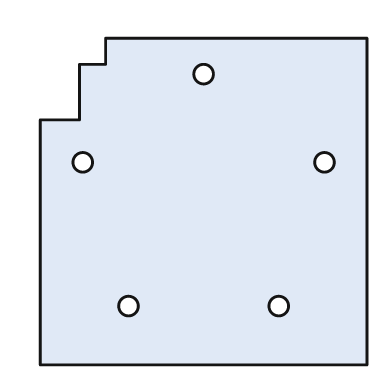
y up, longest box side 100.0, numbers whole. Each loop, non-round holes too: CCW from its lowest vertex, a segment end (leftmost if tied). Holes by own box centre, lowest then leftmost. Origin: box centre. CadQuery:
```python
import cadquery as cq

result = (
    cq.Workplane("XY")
    .moveTo(-50.0, -50.0)
    .lineTo(50.0, -50.0)
    .lineTo(50.0, 50.0)
    .lineTo(-30.0, 50.0)
    .lineTo(-30.0, 42.0)
    .lineTo(-38.0, 42.0)
    .lineTo(-38.0, 25.0)
    .lineTo(-50.0, 25.0)
    .close()
    .moveTo(-23.0, -32.0)
    .circle(3.0)
    .moveTo(23.0, -32.0)
    .circle(3.0)
    .moveTo(-37.0, 12.0)
    .circle(3.0)
    .moveTo(37.0, 12.0)
    .circle(3.0)
    .moveTo(0.0, 39.0)
    .circle(3.0)
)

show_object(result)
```